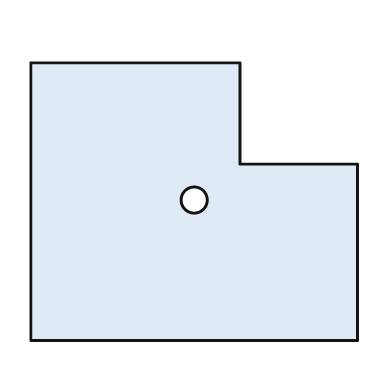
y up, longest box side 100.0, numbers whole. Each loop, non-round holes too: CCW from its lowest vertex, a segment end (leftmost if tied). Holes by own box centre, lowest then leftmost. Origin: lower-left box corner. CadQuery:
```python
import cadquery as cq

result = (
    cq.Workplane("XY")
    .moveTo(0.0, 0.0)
    .lineTo(100.0, 0.0)
    .lineTo(100.0, 54.0)
    .lineTo(64.0, 54.0)
    .lineTo(64.0, 85.0)
    .lineTo(0.0, 85.0)
    .close()
    .moveTo(50.0, 43.0)
    .circle(4.0)
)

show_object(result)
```